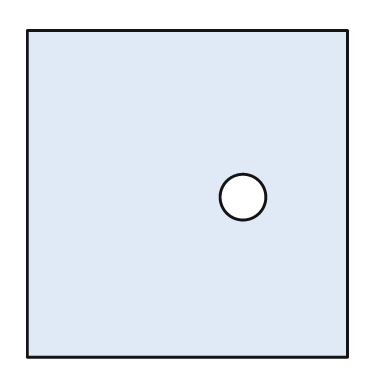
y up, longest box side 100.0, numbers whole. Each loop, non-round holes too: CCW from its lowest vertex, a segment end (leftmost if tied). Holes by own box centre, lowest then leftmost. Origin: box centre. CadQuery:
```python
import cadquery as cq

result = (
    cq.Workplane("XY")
    .moveTo(-49.0, -50.0)
    .lineTo(49.0, -50.0)
    .lineTo(49.0, 50.0)
    .lineTo(-49.0, 50.0)
    .close()
    .moveTo(17.0, -1.0)
    .circle(7.0)
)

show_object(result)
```